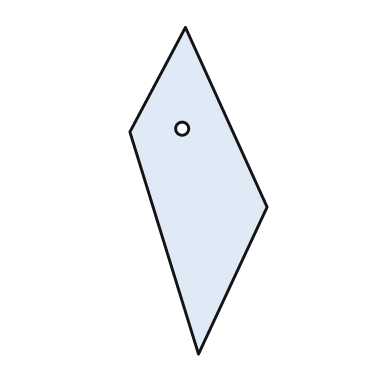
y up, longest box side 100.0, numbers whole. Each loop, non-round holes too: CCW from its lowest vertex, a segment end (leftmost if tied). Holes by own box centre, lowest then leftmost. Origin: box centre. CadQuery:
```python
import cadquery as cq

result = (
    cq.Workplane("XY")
    .moveTo(0.0, -50.0)
    .lineTo(21.0, -5.0)
    .lineTo(-4.0, 50.0)
    .lineTo(-21.0, 18.0)
    .close()
    .moveTo(-5.0, 19.0)
    .circle(2.0)
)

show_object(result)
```